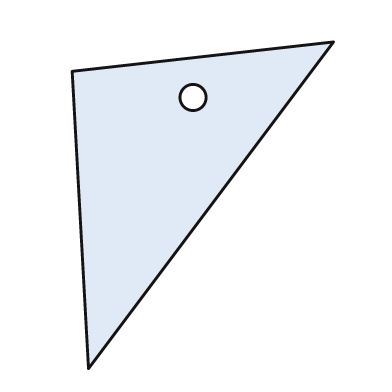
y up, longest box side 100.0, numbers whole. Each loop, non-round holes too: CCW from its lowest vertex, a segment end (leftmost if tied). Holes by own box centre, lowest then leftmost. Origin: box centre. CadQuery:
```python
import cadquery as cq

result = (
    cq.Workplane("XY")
    .moveTo(-35.0, -50.0)
    .lineTo(40.0, 50.0)
    .lineTo(-40.0, 41.0)
    .close()
    .moveTo(-3.0, 33.0)
    .circle(4.0)
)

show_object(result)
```